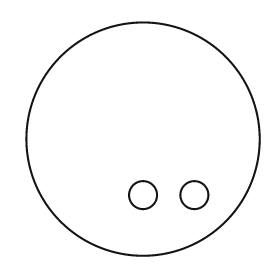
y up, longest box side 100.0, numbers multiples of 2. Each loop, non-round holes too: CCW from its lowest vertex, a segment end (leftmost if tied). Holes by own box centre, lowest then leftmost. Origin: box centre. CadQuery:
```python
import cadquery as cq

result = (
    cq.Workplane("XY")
    .moveTo(0.0, 0.0)
    .circle(50.0)
    .moveTo(0.0, -24.0)
    .circle(6.0)
    .moveTo(22.0, -24.0)
    .circle(6.0)
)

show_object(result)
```